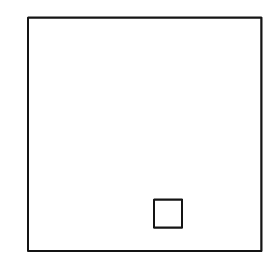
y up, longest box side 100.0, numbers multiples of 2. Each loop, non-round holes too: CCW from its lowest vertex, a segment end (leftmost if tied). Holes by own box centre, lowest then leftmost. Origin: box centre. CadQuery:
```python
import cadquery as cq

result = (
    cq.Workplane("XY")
    .moveTo(-50.0, -50.0)
    .lineTo(50.0, -50.0)
    .lineTo(50.0, 50.0)
    .lineTo(-50.0, 50.0)
    .close()
    .moveTo(4.0, -40.0)
    .lineTo(16.0, -40.0)
    .lineTo(16.0, -28.0)
    .lineTo(4.0, -28.0)
    .close()
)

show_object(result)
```